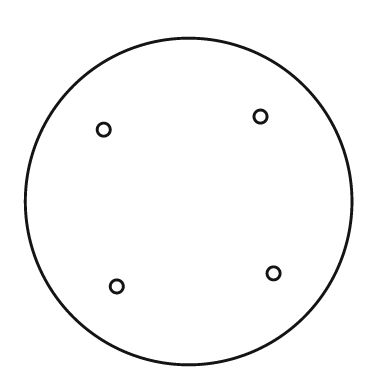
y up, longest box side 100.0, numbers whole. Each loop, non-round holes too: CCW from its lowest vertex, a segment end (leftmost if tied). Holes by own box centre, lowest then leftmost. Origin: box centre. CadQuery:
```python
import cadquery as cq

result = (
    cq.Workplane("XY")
    .moveTo(0.0, 0.0)
    .circle(50.0)
    .moveTo(-22.0, -26.0)
    .circle(2.0)
    .moveTo(26.0, -22.0)
    .circle(2.0)
    .moveTo(-26.0, 22.0)
    .circle(2.0)
    .moveTo(22.0, 26.0)
    .circle(2.0)
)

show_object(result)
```